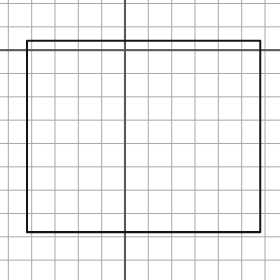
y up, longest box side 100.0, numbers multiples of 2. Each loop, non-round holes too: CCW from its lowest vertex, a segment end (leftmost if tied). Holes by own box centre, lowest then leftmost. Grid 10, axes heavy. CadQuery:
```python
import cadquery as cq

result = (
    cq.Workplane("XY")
    .moveTo(-42.0, -78.0)
    .lineTo(58.0, -78.0)
    .lineTo(58.0, 4.0)
    .lineTo(-42.0, 4.0)
    .close()
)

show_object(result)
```